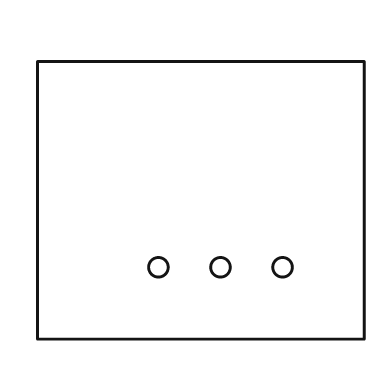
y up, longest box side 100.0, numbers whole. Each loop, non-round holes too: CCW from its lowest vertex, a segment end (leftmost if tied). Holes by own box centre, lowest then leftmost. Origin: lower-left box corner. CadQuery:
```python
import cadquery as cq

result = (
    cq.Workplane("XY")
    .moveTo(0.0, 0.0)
    .lineTo(100.0, 0.0)
    .lineTo(100.0, 85.0)
    .lineTo(0.0, 85.0)
    .close()
    .moveTo(37.0, 22.0)
    .circle(3.0)
    .moveTo(56.0, 22.0)
    .circle(3.0)
    .moveTo(75.0, 22.0)
    .circle(3.0)
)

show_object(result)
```